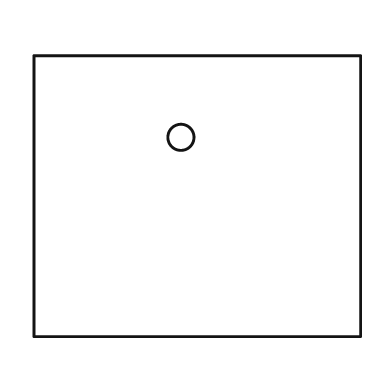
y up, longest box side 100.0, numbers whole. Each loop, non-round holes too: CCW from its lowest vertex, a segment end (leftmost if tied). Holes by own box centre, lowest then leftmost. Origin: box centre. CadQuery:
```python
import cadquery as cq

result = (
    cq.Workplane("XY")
    .moveTo(-50.0, -43.0)
    .lineTo(50.0, -43.0)
    .lineTo(50.0, 43.0)
    .lineTo(-50.0, 43.0)
    .close()
    .moveTo(-5.0, 18.0)
    .circle(4.0)
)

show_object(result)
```